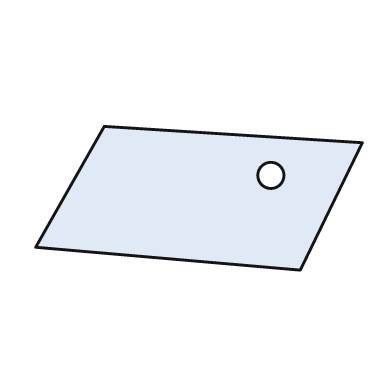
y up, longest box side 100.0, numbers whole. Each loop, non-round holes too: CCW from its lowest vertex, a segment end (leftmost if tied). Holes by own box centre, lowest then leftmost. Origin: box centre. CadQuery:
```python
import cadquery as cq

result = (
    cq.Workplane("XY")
    .moveTo(31.0, -22.0)
    .lineTo(50.0, 17.0)
    .lineTo(-29.0, 22.0)
    .lineTo(-50.0, -15.0)
    .close()
    .moveTo(22.0, 7.0)
    .circle(4.0)
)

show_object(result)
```